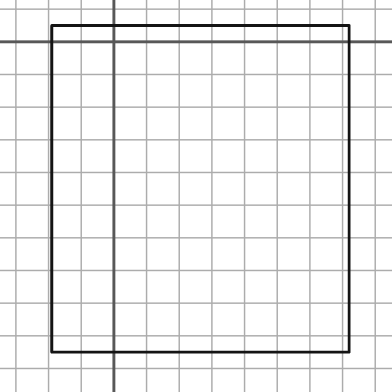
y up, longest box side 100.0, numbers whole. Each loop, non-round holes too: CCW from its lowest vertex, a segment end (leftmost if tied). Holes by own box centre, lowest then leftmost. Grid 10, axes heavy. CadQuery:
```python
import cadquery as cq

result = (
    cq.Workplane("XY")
    .moveTo(-19.0, -95.0)
    .lineTo(72.0, -95.0)
    .lineTo(72.0, 5.0)
    .lineTo(-19.0, 5.0)
    .close()
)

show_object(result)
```